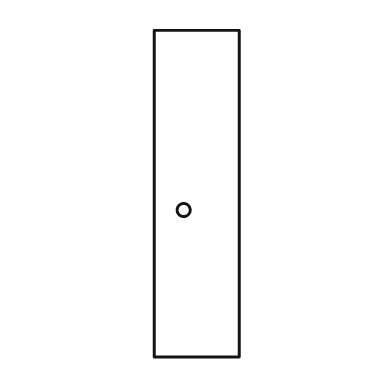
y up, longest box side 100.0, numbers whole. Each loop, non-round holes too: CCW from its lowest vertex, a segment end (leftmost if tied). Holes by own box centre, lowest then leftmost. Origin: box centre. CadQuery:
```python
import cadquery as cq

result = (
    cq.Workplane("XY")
    .moveTo(-13.0, -50.0)
    .lineTo(13.0, -50.0)
    .lineTo(13.0, 50.0)
    .lineTo(-13.0, 50.0)
    .close()
    .moveTo(-4.0, -5.0)
    .circle(2.0)
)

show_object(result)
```